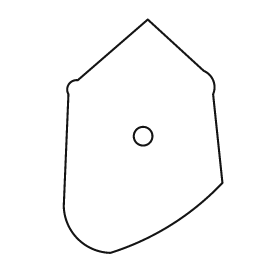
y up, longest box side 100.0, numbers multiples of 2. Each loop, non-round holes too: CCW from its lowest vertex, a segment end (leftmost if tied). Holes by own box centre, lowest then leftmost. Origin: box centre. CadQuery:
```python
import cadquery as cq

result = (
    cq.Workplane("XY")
    .moveTo(-14.0, -50.0)
    .threePointArc((12.0, -38.0), (34.0, -20.0))
    .lineTo(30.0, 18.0)
    .threePointArc((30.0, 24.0), (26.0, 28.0))
    .lineTo(2.0, 50.0)
    .lineTo(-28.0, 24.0)
    .threePointArc((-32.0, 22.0), (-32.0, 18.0))
    .lineTo(-34.0, -30.0)
    .threePointArc((-28.0, -44.0), (-14.0, -50.0))
    .close()
    .moveTo(0.0, 0.0)
    .circle(4.0)
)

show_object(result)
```